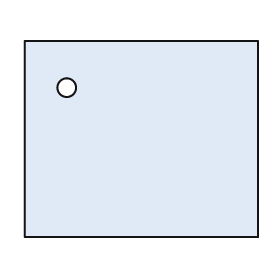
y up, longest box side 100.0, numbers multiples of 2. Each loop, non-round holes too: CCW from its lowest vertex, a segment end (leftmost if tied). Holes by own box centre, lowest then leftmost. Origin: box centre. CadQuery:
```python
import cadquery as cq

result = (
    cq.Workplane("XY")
    .moveTo(-50.0, -42.0)
    .lineTo(50.0, -42.0)
    .lineTo(50.0, 42.0)
    .lineTo(-50.0, 42.0)
    .close()
    .moveTo(-32.0, 22.0)
    .circle(4.0)
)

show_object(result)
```